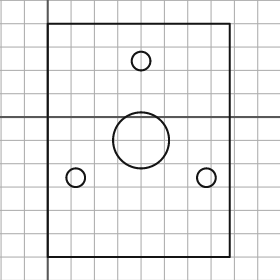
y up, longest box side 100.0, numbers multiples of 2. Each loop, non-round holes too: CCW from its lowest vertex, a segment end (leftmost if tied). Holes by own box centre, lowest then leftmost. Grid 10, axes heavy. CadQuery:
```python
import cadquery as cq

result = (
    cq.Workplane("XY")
    .moveTo(0.0, -60.0)
    .lineTo(78.0, -60.0)
    .lineTo(78.0, 40.0)
    .lineTo(0.0, 40.0)
    .close()
    .moveTo(12.0, -26.0)
    .circle(4.0)
    .moveTo(68.0, -26.0)
    .circle(4.0)
    .moveTo(40.0, -10.0)
    .circle(12.0)
    .moveTo(40.0, 24.0)
    .circle(4.0)
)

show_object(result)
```